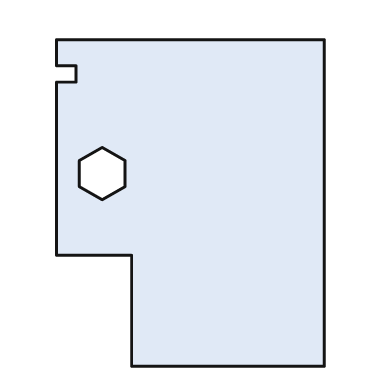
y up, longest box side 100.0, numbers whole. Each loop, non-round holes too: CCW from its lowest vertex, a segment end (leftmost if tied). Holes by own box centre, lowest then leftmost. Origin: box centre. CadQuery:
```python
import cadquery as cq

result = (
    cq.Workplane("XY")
    .moveTo(-18.0, -50.0)
    .lineTo(41.0, -50.0)
    .lineTo(41.0, 50.0)
    .lineTo(-41.0, 50.0)
    .lineTo(-41.0, 42.0)
    .lineTo(-35.0, 42.0)
    .lineTo(-35.0, 37.0)
    .lineTo(-41.0, 37.0)
    .lineTo(-41.0, -16.0)
    .lineTo(-18.0, -16.0)
    .close()
    .moveTo(-27.0, 1.0)
    .lineTo(-20.0, 5.0)
    .lineTo(-20.0, 13.0)
    .lineTo(-27.0, 17.0)
    .lineTo(-34.0, 13.0)
    .lineTo(-34.0, 5.0)
    .close()
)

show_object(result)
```